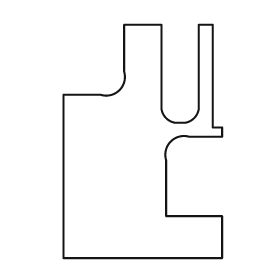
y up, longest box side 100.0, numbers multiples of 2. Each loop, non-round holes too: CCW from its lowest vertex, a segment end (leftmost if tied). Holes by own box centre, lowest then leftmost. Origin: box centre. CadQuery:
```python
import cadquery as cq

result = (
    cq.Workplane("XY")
    .moveTo(-34.0, -50.0)
    .lineTo(34.0, -50.0)
    .lineTo(34.0, -32.0)
    .lineTo(10.0, -32.0)
    .lineTo(10.0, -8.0)
    .threePointArc((12.0, 0.0), (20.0, 2.0))
    .lineTo(34.0, 2.0)
    .lineTo(34.0, 6.0)
    .lineTo(30.0, 6.0)
    .lineTo(30.0, 50.0)
    .lineTo(24.0, 50.0)
    .lineTo(24.0, 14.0)
    .threePointArc((22.0, 10.0), (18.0, 8.0))
    .lineTo(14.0, 8.0)
    .threePointArc((10.0, 10.0), (8.0, 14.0))
    .lineTo(8.0, 50.0)
    .lineTo(-8.0, 50.0)
    .lineTo(-8.0, 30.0)
    .threePointArc((-10.0, 22.0), (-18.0, 20.0))
    .lineTo(-34.0, 20.0)
    .close()
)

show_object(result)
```